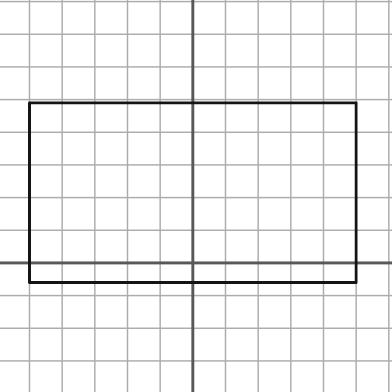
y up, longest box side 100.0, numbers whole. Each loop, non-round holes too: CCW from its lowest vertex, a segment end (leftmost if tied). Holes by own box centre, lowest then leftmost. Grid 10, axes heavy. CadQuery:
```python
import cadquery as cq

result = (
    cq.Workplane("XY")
    .moveTo(-50.0, -6.0)
    .lineTo(50.0, -6.0)
    .lineTo(50.0, 49.0)
    .lineTo(-50.0, 49.0)
    .close()
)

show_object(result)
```